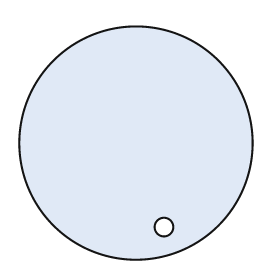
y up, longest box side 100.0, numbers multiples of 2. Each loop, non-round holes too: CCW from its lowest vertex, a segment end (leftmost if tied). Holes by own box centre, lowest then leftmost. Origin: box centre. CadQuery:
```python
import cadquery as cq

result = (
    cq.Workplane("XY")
    .moveTo(0.0, 0.0)
    .circle(50.0)
    .moveTo(12.0, -36.0)
    .circle(4.0)
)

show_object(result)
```